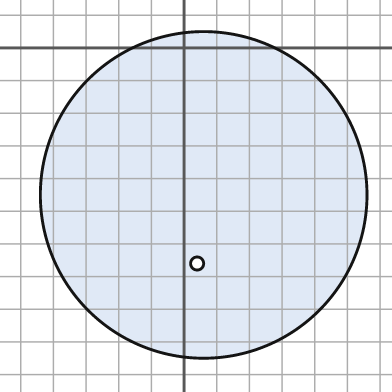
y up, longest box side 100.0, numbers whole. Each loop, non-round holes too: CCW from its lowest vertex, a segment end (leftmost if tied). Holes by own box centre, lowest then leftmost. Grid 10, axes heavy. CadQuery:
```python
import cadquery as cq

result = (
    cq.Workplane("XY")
    .moveTo(6.0, -45.0)
    .circle(50.0)
    .moveTo(4.0, -66.0)
    .circle(2.0)
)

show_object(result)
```